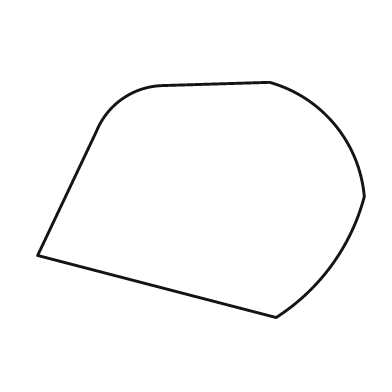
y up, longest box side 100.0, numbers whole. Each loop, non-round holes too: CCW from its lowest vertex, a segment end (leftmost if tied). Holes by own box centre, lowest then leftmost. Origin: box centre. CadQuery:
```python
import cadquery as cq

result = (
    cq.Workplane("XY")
    .moveTo(23.0, -36.0)
    .threePointArc((40.0, -20.0), (50.0, 1.0))
    .threePointArc((41.0, 23.0), (21.0, 36.0))
    .lineTo(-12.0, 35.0)
    .threePointArc((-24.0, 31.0), (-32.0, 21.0))
    .lineTo(-50.0, -17.0)
    .close()
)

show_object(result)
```